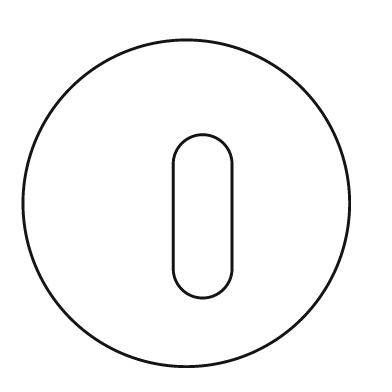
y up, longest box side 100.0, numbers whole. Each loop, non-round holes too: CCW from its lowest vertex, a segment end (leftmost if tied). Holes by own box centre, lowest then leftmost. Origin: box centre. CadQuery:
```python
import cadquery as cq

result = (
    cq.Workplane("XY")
    .moveTo(0.0, 0.0)
    .circle(50.0)
    .moveTo(-4.0, -20.0)
    .threePointArc((5.0, -29.0), (14.0, -20.0))
    .lineTo(14.0, 12.0)
    .threePointArc((5.0, 21.0), (-4.0, 12.0))
    .close()
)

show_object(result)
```